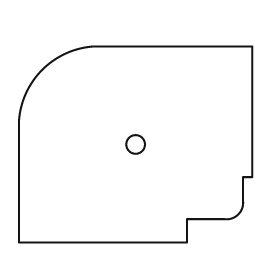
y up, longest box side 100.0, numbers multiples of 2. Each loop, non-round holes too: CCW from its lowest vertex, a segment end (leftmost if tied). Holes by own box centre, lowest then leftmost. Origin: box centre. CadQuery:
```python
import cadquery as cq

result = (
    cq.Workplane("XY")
    .moveTo(-50.0, -42.0)
    .lineTo(22.0, -42.0)
    .lineTo(22.0, -32.0)
    .lineTo(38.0, -32.0)
    .threePointArc((44.0, -30.0), (46.0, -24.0))
    .lineTo(46.0, -14.0)
    .lineTo(50.0, -14.0)
    .lineTo(50.0, 42.0)
    .lineTo(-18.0, 42.0)
    .threePointArc((-40.0, 32.0), (-50.0, 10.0))
    .close()
    .moveTo(0.0, 0.0)
    .circle(4.0)
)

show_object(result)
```